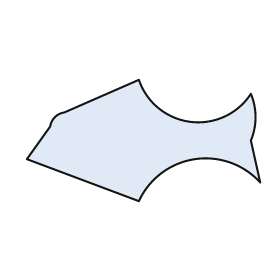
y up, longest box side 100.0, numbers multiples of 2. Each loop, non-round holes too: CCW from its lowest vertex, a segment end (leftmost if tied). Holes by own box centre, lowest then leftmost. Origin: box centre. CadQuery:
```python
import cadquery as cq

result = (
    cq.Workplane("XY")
    .moveTo(-2.0, -26.0)
    .threePointArc((22.0, -8.0), (50.0, -18.0))
    .lineTo(46.0, 0.0)
    .threePointArc((48.0, 10.0), (46.0, 20.0))
    .threePointArc((20.0, 8.0), (-2.0, 26.0))
    .lineTo(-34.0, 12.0)
    .threePointArc((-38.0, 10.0), (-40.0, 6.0))
    .lineTo(-50.0, -8.0)
    .close()
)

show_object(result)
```